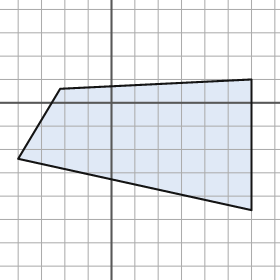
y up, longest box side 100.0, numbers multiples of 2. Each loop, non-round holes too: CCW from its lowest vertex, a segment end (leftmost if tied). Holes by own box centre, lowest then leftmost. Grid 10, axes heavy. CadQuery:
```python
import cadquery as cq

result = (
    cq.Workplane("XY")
    .moveTo(60.0, -46.0)
    .lineTo(60.0, 10.0)
    .lineTo(-22.0, 6.0)
    .lineTo(-40.0, -24.0)
    .close()
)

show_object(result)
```